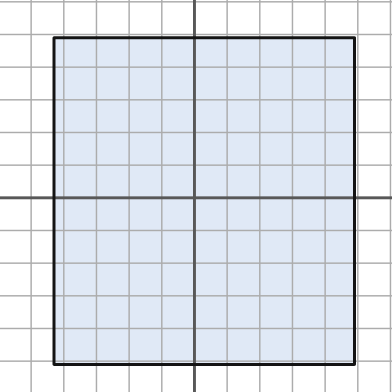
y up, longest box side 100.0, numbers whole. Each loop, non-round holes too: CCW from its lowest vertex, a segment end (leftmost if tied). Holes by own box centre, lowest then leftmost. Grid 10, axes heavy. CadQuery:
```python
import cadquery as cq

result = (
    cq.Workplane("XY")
    .moveTo(-43.0, -51.0)
    .lineTo(49.0, -51.0)
    .lineTo(49.0, 49.0)
    .lineTo(-43.0, 49.0)
    .close()
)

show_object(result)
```